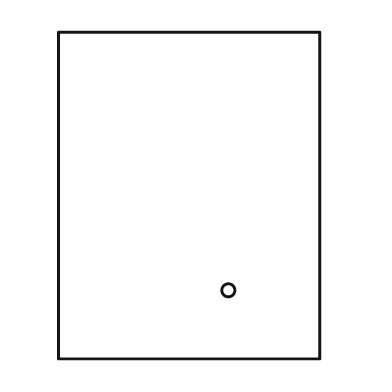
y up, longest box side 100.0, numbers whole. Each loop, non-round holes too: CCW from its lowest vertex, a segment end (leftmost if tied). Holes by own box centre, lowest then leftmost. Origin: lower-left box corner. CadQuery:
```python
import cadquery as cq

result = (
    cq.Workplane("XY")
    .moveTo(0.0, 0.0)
    .lineTo(80.0, 0.0)
    .lineTo(80.0, 100.0)
    .lineTo(0.0, 100.0)
    .close()
    .moveTo(52.0, 21.0)
    .circle(2.0)
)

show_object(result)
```